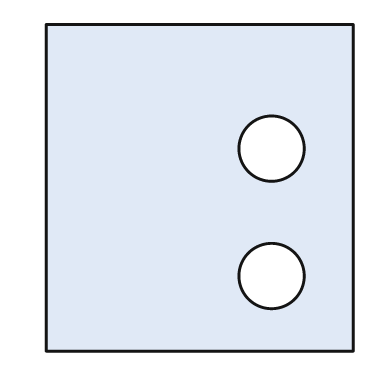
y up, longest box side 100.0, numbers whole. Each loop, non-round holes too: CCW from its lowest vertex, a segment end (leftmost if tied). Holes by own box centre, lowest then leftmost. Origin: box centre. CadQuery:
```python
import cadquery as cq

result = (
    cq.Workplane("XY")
    .moveTo(-47.0, -50.0)
    .lineTo(47.0, -50.0)
    .lineTo(47.0, 50.0)
    .lineTo(-47.0, 50.0)
    .close()
    .moveTo(22.0, -27.0)
    .circle(10.0)
    .moveTo(22.0, 12.0)
    .circle(10.0)
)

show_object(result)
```